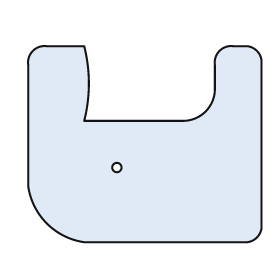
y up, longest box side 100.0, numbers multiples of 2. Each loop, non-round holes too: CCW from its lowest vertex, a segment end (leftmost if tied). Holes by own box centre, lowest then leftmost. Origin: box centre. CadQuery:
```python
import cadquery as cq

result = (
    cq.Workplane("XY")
    .moveTo(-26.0, -42.0)
    .lineTo(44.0, -42.0)
    .threePointArc((48.0, -40.0), (50.0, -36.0))
    .lineTo(50.0, 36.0)
    .threePointArc((48.0, 40.0), (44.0, 42.0))
    .lineTo(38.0, 42.0)
    .threePointArc((32.0, 40.0), (30.0, 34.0))
    .lineTo(30.0, 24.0)
    .threePointArc((26.0, 14.0), (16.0, 10.0))
    .lineTo(-26.0, 10.0)
    .threePointArc((-24.0, 26.0), (-26.0, 42.0))
    .lineTo(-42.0, 42.0)
    .threePointArc((-48.0, 40.0), (-50.0, 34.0))
    .lineTo(-50.0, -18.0)
    .threePointArc((-42.0, -34.0), (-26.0, -42.0))
    .close()
    .moveTo(-12.0, -10.0)
    .circle(2.0)
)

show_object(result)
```